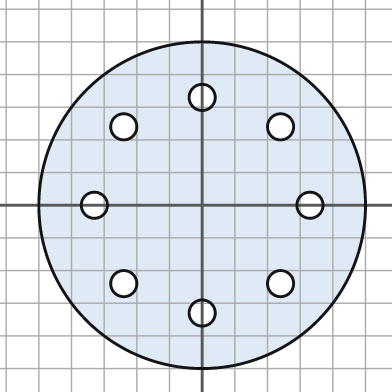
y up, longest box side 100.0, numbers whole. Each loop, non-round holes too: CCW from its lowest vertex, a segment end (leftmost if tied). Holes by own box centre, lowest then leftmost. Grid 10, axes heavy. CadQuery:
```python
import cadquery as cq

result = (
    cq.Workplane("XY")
    .moveTo(0.0, 0.0)
    .circle(50.0)
    .moveTo(0.0, -33.0)
    .circle(4.0)
    .moveTo(-24.0, -24.0)
    .circle(4.0)
    .moveTo(24.0, -24.0)
    .circle(4.0)
    .moveTo(-33.0, 0.0)
    .circle(4.0)
    .moveTo(33.0, 0.0)
    .circle(4.0)
    .moveTo(-24.0, 24.0)
    .circle(4.0)
    .moveTo(24.0, 24.0)
    .circle(4.0)
    .moveTo(0.0, 33.0)
    .circle(4.0)
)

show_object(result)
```